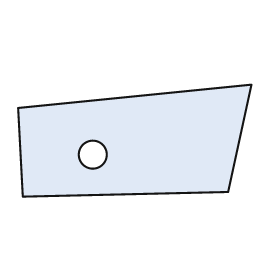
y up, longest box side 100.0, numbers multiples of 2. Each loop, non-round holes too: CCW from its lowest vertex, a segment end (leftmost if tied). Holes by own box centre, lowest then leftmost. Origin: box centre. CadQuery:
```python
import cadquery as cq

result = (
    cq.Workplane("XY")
    .moveTo(-48.0, -24.0)
    .lineTo(40.0, -22.0)
    .lineTo(50.0, 24.0)
    .lineTo(-50.0, 14.0)
    .close()
    .moveTo(-18.0, -6.0)
    .circle(6.0)
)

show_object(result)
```